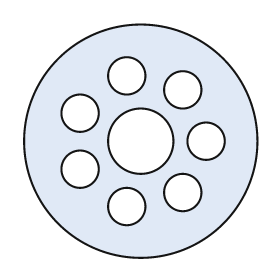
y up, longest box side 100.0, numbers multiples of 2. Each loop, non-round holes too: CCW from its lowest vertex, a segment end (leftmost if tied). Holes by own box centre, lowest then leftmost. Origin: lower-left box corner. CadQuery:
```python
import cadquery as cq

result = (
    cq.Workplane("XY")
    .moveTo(50.0, 50.0)
    .circle(50.0)
    .moveTo(44.0, 22.0)
    .circle(8.0)
    .moveTo(68.0, 28.0)
    .circle(8.0)
    .moveTo(24.0, 38.0)
    .circle(8.0)
    .moveTo(50.0, 50.0)
    .circle(14.0)
    .moveTo(78.0, 50.0)
    .circle(8.0)
    .moveTo(24.0, 62.0)
    .circle(8.0)
    .moveTo(68.0, 72.0)
    .circle(8.0)
    .moveTo(44.0, 78.0)
    .circle(8.0)
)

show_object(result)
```